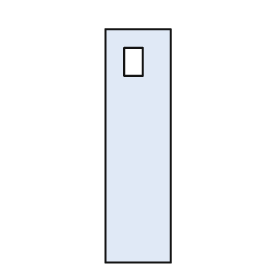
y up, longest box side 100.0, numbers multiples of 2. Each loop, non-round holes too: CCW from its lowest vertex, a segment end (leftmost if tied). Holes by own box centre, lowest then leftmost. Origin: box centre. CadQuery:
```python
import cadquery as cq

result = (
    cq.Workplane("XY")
    .moveTo(-14.0, -50.0)
    .lineTo(14.0, -50.0)
    .lineTo(14.0, 50.0)
    .lineTo(-14.0, 50.0)
    .close()
    .moveTo(-6.0, 30.0)
    .lineTo(2.0, 30.0)
    .lineTo(2.0, 42.0)
    .lineTo(-6.0, 42.0)
    .close()
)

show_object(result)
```